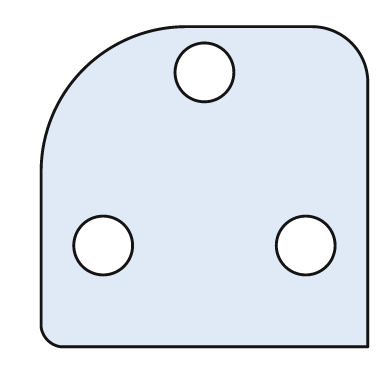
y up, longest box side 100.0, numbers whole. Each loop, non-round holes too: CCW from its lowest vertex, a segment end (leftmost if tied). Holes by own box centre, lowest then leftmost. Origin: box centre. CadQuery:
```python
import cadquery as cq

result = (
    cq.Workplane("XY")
    .moveTo(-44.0, -49.0)
    .lineTo(50.0, -49.0)
    .lineTo(50.0, 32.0)
    .threePointArc((45.0, 44.0), (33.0, 49.0))
    .lineTo(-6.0, 49.0)
    .threePointArc((-37.0, 36.0), (-50.0, 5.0))
    .lineTo(-50.0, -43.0)
    .threePointArc((-48.0, -47.0), (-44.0, -49.0))
    .close()
    .moveTo(-31.0, -18.0)
    .circle(9.0)
    .moveTo(31.0, -18.0)
    .circle(9.0)
    .moveTo(0.0, 35.0)
    .circle(9.0)
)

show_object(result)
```